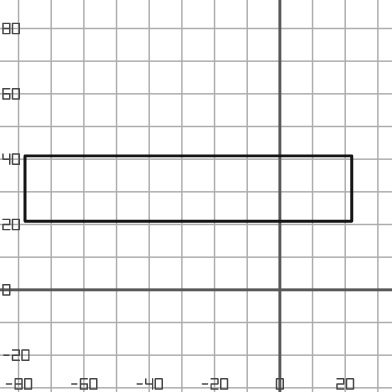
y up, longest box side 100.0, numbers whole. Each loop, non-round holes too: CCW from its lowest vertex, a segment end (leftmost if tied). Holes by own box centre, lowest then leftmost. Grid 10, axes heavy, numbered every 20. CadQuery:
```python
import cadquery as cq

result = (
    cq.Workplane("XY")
    .moveTo(-78.0, 21.0)
    .lineTo(22.0, 21.0)
    .lineTo(22.0, 41.0)
    .lineTo(-78.0, 41.0)
    .close()
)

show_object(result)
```